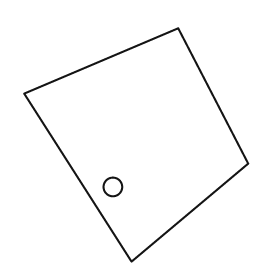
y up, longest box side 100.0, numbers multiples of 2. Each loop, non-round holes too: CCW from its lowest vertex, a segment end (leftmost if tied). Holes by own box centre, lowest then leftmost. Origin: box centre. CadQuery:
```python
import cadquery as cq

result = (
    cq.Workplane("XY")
    .moveTo(-2.0, -50.0)
    .lineTo(48.0, -8.0)
    .lineTo(18.0, 50.0)
    .lineTo(-48.0, 22.0)
    .close()
    .moveTo(-10.0, -18.0)
    .circle(4.0)
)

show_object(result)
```